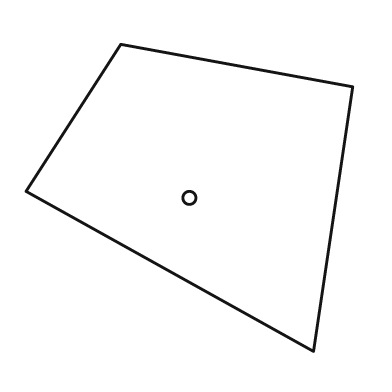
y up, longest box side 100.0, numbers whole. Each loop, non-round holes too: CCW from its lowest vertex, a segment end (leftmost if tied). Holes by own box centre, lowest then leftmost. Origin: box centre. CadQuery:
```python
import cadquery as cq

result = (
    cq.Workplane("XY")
    .moveTo(38.0, -47.0)
    .lineTo(50.0, 34.0)
    .lineTo(-21.0, 47.0)
    .lineTo(-50.0, 2.0)
    .close()
    .moveTo(0.0, 0.0)
    .circle(2.0)
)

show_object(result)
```